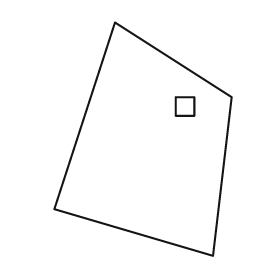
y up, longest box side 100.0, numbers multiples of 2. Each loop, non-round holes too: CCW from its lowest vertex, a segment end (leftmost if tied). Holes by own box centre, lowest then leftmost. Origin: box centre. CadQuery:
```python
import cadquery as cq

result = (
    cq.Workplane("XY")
    .moveTo(30.0, -50.0)
    .lineTo(38.0, 18.0)
    .lineTo(-12.0, 50.0)
    .lineTo(-38.0, -30.0)
    .close()
    .moveTo(14.0, 10.0)
    .lineTo(22.0, 10.0)
    .lineTo(22.0, 18.0)
    .lineTo(14.0, 18.0)
    .close()
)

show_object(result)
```